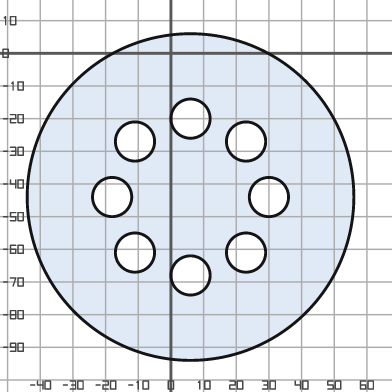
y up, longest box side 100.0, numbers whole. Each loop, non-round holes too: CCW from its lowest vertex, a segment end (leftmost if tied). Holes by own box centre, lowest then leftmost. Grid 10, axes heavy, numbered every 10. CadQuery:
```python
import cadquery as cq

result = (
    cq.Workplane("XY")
    .moveTo(6.0, -44.0)
    .circle(50.0)
    .moveTo(6.0, -68.0)
    .circle(6.0)
    .moveTo(-11.0, -61.0)
    .circle(6.0)
    .moveTo(23.0, -61.0)
    .circle(6.0)
    .moveTo(-18.0, -44.0)
    .circle(6.0)
    .moveTo(30.0, -44.0)
    .circle(6.0)
    .moveTo(-11.0, -27.0)
    .circle(6.0)
    .moveTo(23.0, -27.0)
    .circle(6.0)
    .moveTo(6.0, -20.0)
    .circle(6.0)
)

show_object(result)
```